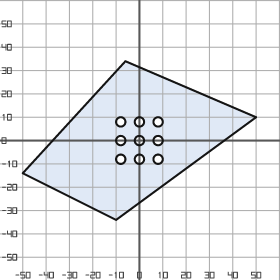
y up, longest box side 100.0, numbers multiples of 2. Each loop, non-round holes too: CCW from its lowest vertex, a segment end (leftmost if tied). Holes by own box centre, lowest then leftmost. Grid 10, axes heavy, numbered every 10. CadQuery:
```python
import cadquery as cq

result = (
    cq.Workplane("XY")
    .moveTo(-10.0, -34.0)
    .lineTo(50.0, 10.0)
    .lineTo(-6.0, 34.0)
    .lineTo(-50.0, -14.0)
    .close()
    .moveTo(-8.0, -8.0)
    .circle(2.0)
    .moveTo(0.0, -8.0)
    .circle(2.0)
    .moveTo(8.0, -8.0)
    .circle(2.0)
    .moveTo(-8.0, 0.0)
    .circle(2.0)
    .moveTo(0.0, 0.0)
    .circle(2.0)
    .moveTo(8.0, 0.0)
    .circle(2.0)
    .moveTo(-8.0, 8.0)
    .circle(2.0)
    .moveTo(0.0, 8.0)
    .circle(2.0)
    .moveTo(8.0, 8.0)
    .circle(2.0)
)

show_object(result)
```